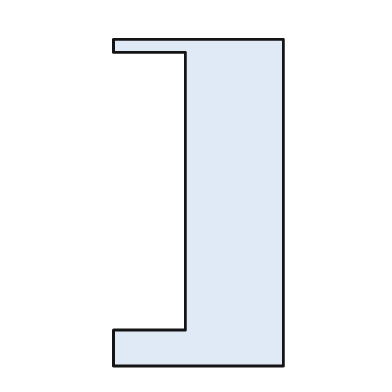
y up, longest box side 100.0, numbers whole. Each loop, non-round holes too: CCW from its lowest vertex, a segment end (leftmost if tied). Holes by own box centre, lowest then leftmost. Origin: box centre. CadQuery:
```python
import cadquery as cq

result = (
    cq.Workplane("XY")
    .moveTo(-26.0, -50.0)
    .lineTo(26.0, -50.0)
    .lineTo(26.0, 50.0)
    .lineTo(-26.0, 50.0)
    .lineTo(-26.0, 46.0)
    .lineTo(-4.0, 46.0)
    .lineTo(-4.0, -39.0)
    .lineTo(-26.0, -39.0)
    .close()
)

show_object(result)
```